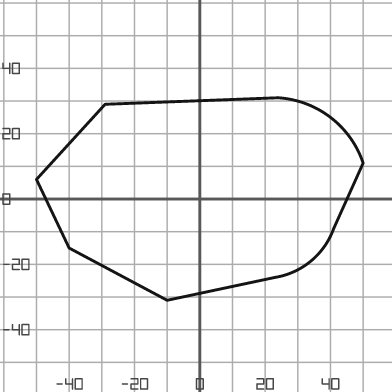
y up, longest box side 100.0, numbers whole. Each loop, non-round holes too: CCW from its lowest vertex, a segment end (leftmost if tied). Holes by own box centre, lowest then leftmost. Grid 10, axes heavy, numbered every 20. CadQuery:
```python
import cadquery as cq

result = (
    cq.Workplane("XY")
    .moveTo(-10.0, -31.0)
    .lineTo(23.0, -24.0)
    .threePointArc((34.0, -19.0), (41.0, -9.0))
    .lineTo(50.0, 11.0)
    .threePointArc((40.0, 25.0), (24.0, 31.0))
    .lineTo(-29.0, 29.0)
    .lineTo(-50.0, 6.0)
    .lineTo(-40.0, -15.0)
    .close()
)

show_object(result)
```